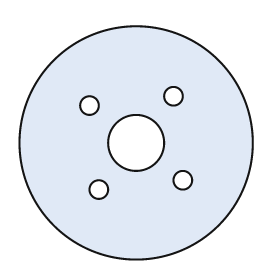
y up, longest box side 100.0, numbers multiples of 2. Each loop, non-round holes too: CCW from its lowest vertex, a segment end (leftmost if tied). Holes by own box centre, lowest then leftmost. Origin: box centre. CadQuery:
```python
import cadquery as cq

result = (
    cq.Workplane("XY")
    .moveTo(0.0, 0.0)
    .circle(50.0)
    .moveTo(-16.0, -20.0)
    .circle(4.0)
    .moveTo(20.0, -16.0)
    .circle(4.0)
    .moveTo(0.0, 0.0)
    .circle(12.0)
    .moveTo(-20.0, 16.0)
    .circle(4.0)
    .moveTo(16.0, 20.0)
    .circle(4.0)
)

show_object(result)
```